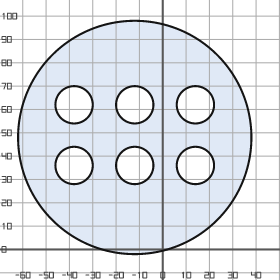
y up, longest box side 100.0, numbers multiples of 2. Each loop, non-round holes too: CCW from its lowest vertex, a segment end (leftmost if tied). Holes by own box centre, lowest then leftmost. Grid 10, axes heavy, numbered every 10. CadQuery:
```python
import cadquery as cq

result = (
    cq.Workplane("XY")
    .moveTo(-12.0, 48.0)
    .circle(50.0)
    .moveTo(-38.0, 36.0)
    .circle(8.0)
    .moveTo(-12.0, 36.0)
    .circle(8.0)
    .moveTo(14.0, 36.0)
    .circle(8.0)
    .moveTo(-38.0, 62.0)
    .circle(8.0)
    .moveTo(-12.0, 62.0)
    .circle(8.0)
    .moveTo(14.0, 62.0)
    .circle(8.0)
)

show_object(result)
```